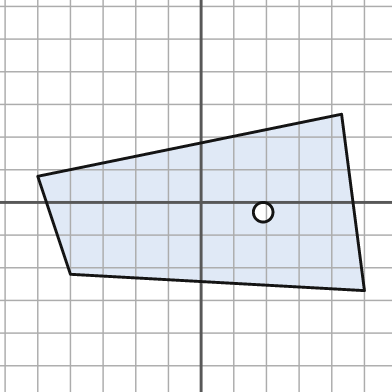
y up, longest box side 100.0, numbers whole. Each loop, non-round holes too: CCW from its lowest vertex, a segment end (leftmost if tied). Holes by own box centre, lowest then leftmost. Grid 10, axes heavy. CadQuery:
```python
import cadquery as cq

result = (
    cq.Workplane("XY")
    .moveTo(50.0, -27.0)
    .lineTo(43.0, 27.0)
    .lineTo(-50.0, 8.0)
    .lineTo(-40.0, -22.0)
    .close()
    .moveTo(19.0, -3.0)
    .circle(3.0)
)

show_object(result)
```